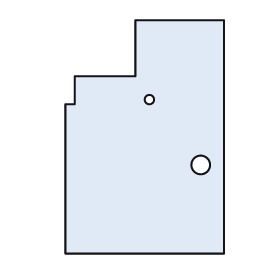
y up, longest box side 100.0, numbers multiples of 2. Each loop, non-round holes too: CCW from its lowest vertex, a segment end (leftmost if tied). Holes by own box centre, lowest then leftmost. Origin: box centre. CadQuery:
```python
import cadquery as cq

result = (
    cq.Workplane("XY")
    .moveTo(-34.0, -50.0)
    .lineTo(34.0, -50.0)
    .lineTo(34.0, 50.0)
    .lineTo(-4.0, 50.0)
    .lineTo(-4.0, 26.0)
    .lineTo(-30.0, 26.0)
    .lineTo(-30.0, 14.0)
    .lineTo(-34.0, 14.0)
    .close()
    .moveTo(24.0, -12.0)
    .circle(4.0)
    .moveTo(2.0, 16.0)
    .circle(2.0)
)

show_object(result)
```